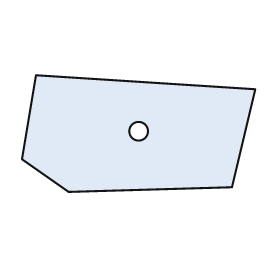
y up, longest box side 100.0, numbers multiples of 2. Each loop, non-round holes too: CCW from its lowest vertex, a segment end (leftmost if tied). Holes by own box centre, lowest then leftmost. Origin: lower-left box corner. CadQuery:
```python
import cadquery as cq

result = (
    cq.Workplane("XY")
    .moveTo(20.0, 0.0)
    .lineTo(90.0, 2.0)
    .lineTo(100.0, 44.0)
    .lineTo(6.0, 50.0)
    .lineTo(0.0, 14.0)
    .close()
    .moveTo(50.0, 26.0)
    .circle(4.0)
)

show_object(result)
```